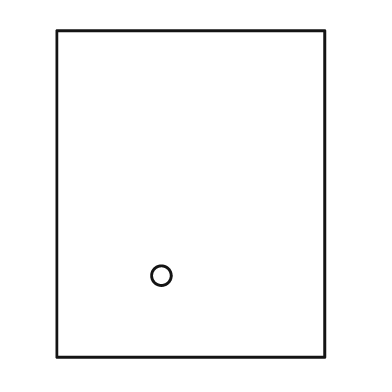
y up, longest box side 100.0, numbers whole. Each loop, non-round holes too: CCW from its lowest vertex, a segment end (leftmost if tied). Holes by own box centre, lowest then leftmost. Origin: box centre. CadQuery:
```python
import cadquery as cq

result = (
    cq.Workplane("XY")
    .moveTo(-41.0, -50.0)
    .lineTo(41.0, -50.0)
    .lineTo(41.0, 50.0)
    .lineTo(-41.0, 50.0)
    .close()
    .moveTo(-9.0, -25.0)
    .circle(3.0)
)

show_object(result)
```